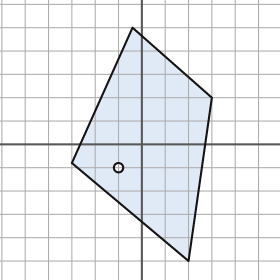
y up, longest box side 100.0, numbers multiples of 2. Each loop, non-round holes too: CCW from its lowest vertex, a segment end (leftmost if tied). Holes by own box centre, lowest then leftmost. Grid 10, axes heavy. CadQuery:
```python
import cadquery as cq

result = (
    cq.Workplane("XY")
    .moveTo(20.0, -50.0)
    .lineTo(30.0, 20.0)
    .lineTo(-4.0, 50.0)
    .lineTo(-30.0, -8.0)
    .close()
    .moveTo(-10.0, -10.0)
    .circle(2.0)
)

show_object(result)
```